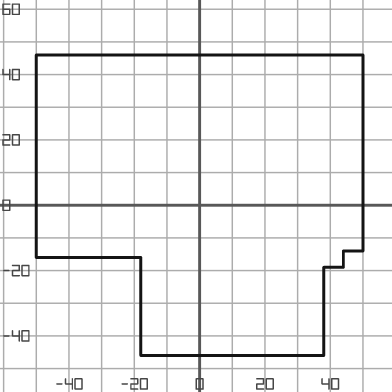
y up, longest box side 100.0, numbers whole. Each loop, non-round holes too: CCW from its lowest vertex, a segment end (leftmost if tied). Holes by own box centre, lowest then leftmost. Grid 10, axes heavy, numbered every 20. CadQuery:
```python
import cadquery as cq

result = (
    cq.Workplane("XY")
    .moveTo(-18.0, -46.0)
    .lineTo(38.0, -46.0)
    .lineTo(38.0, -19.0)
    .lineTo(44.0, -19.0)
    .lineTo(44.0, -14.0)
    .lineTo(50.0, -14.0)
    .lineTo(50.0, 46.0)
    .lineTo(-50.0, 46.0)
    .lineTo(-50.0, -16.0)
    .lineTo(-18.0, -16.0)
    .close()
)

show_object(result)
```